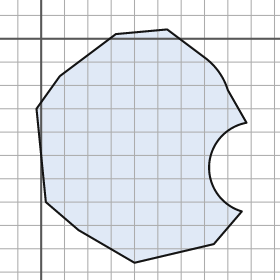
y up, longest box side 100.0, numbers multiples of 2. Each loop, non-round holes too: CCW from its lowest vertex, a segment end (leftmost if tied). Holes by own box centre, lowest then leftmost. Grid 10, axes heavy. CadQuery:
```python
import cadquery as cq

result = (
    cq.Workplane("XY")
    .moveTo(40.0, -96.0)
    .lineTo(74.0, -88.0)
    .lineTo(86.0, -74.0)
    .threePointArc((72.0, -54.0), (88.0, -36.0))
    .lineTo(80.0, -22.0)
    .threePointArc((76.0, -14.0), (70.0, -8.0))
    .lineTo(54.0, 4.0)
    .lineTo(32.0, 2.0)
    .lineTo(8.0, -16.0)
    .lineTo(-2.0, -30.0)
    .lineTo(2.0, -70.0)
    .lineTo(16.0, -82.0)
    .close()
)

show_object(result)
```